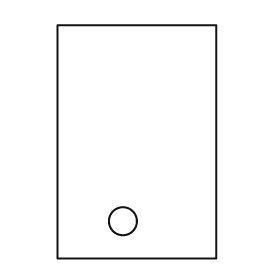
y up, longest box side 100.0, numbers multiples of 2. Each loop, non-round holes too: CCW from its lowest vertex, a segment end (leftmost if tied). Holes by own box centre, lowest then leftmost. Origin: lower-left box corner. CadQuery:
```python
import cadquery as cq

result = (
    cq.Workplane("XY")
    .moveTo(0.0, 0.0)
    .lineTo(68.0, 0.0)
    .lineTo(68.0, 100.0)
    .lineTo(0.0, 100.0)
    .close()
    .moveTo(28.0, 16.0)
    .circle(6.0)
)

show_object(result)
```